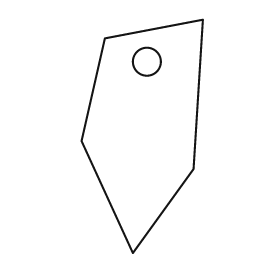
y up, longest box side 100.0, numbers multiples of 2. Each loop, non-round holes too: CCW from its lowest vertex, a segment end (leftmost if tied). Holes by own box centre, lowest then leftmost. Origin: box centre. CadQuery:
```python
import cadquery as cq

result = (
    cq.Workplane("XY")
    .moveTo(-4.0, -50.0)
    .lineTo(22.0, -14.0)
    .lineTo(26.0, 50.0)
    .lineTo(-16.0, 42.0)
    .lineTo(-26.0, -2.0)
    .close()
    .moveTo(2.0, 32.0)
    .circle(6.0)
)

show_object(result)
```